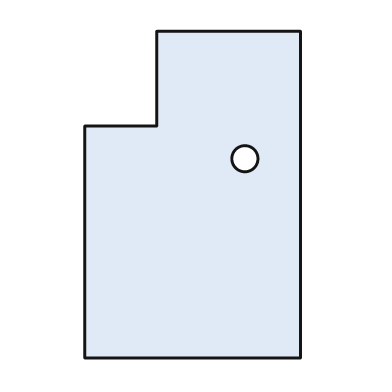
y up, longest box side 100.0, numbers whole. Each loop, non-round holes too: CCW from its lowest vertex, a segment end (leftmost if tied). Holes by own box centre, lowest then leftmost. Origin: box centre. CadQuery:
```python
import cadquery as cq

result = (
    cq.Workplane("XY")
    .moveTo(-33.0, -50.0)
    .lineTo(33.0, -50.0)
    .lineTo(33.0, 50.0)
    .lineTo(-11.0, 50.0)
    .lineTo(-11.0, 21.0)
    .lineTo(-33.0, 21.0)
    .close()
    .moveTo(16.0, 11.0)
    .circle(4.0)
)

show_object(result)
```